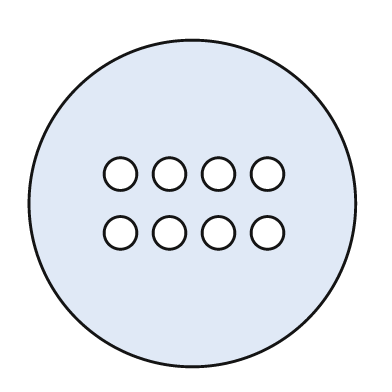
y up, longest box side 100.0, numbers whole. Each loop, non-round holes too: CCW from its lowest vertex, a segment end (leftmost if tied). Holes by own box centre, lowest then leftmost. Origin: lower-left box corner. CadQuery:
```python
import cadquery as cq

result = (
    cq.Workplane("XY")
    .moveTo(50.0, 50.0)
    .circle(50.0)
    .moveTo(28.0, 41.0)
    .circle(5.0)
    .moveTo(43.0, 41.0)
    .circle(5.0)
    .moveTo(58.0, 41.0)
    .circle(5.0)
    .moveTo(73.0, 41.0)
    .circle(5.0)
    .moveTo(28.0, 59.0)
    .circle(5.0)
    .moveTo(43.0, 59.0)
    .circle(5.0)
    .moveTo(58.0, 59.0)
    .circle(5.0)
    .moveTo(73.0, 59.0)
    .circle(5.0)
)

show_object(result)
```